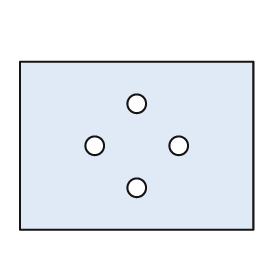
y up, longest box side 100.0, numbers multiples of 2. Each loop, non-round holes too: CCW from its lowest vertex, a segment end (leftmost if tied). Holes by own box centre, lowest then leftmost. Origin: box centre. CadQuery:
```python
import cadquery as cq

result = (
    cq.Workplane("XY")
    .moveTo(-50.0, -36.0)
    .lineTo(50.0, -36.0)
    .lineTo(50.0, 36.0)
    .lineTo(-50.0, 36.0)
    .close()
    .moveTo(0.0, -18.0)
    .circle(4.0)
    .moveTo(-18.0, 0.0)
    .circle(4.0)
    .moveTo(18.0, 0.0)
    .circle(4.0)
    .moveTo(0.0, 18.0)
    .circle(4.0)
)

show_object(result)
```